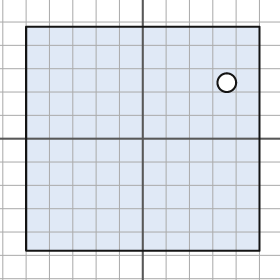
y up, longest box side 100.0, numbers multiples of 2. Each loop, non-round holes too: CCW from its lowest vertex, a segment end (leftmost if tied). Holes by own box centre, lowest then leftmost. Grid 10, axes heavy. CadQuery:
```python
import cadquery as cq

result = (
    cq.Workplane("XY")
    .moveTo(-50.0, -48.0)
    .lineTo(50.0, -48.0)
    .lineTo(50.0, 48.0)
    .lineTo(-50.0, 48.0)
    .close()
    .moveTo(36.0, 24.0)
    .circle(4.0)
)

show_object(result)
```